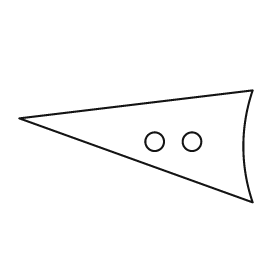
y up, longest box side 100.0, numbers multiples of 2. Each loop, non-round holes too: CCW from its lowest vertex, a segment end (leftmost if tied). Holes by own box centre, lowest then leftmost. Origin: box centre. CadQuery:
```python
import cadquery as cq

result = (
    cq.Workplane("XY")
    .moveTo(50.0, -24.0)
    .threePointArc((46.0, 0.0), (50.0, 24.0))
    .lineTo(-50.0, 12.0)
    .close()
    .moveTo(8.0, 2.0)
    .circle(4.0)
    .moveTo(24.0, 2.0)
    .circle(4.0)
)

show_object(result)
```